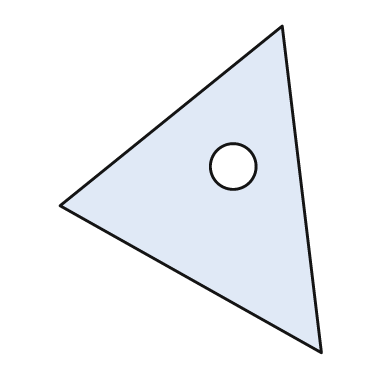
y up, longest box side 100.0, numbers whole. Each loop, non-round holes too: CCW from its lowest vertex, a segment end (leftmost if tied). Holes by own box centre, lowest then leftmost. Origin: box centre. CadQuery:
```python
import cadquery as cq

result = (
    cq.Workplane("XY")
    .moveTo(40.0, -50.0)
    .lineTo(28.0, 50.0)
    .lineTo(-40.0, -5.0)
    .close()
    .moveTo(13.0, 7.0)
    .circle(7.0)
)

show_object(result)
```